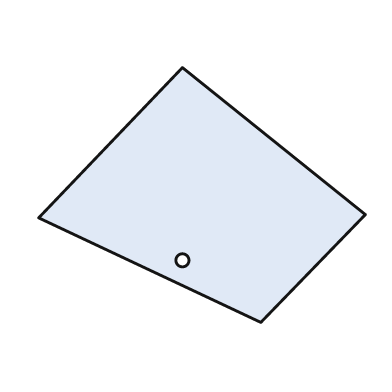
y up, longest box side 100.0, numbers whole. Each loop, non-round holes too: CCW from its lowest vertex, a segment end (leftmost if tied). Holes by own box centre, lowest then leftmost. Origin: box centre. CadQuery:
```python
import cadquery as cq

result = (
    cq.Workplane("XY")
    .moveTo(18.0, -39.0)
    .lineTo(50.0, -6.0)
    .lineTo(-6.0, 39.0)
    .lineTo(-50.0, -7.0)
    .close()
    .moveTo(-6.0, -20.0)
    .circle(2.0)
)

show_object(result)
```